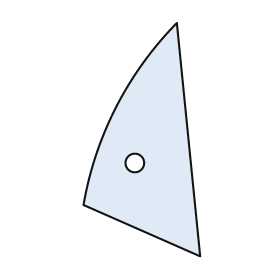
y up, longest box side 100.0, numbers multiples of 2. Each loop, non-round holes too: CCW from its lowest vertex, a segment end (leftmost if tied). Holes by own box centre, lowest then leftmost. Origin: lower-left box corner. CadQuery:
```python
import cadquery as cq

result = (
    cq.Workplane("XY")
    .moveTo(50.0, 0.0)
    .lineTo(40.0, 100.0)
    .threePointArc((14.0, 64.0), (0.0, 22.0))
    .close()
    .moveTo(22.0, 40.0)
    .circle(4.0)
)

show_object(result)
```